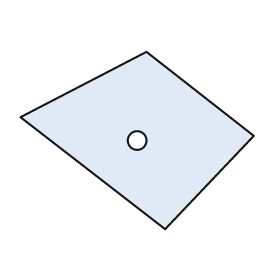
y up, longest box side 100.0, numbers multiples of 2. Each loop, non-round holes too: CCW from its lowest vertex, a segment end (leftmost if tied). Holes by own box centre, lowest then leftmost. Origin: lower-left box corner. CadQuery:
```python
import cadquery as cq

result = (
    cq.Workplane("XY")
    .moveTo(62.0, 0.0)
    .lineTo(100.0, 40.0)
    .lineTo(54.0, 76.0)
    .lineTo(0.0, 48.0)
    .close()
    .moveTo(50.0, 38.0)
    .circle(4.0)
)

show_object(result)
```